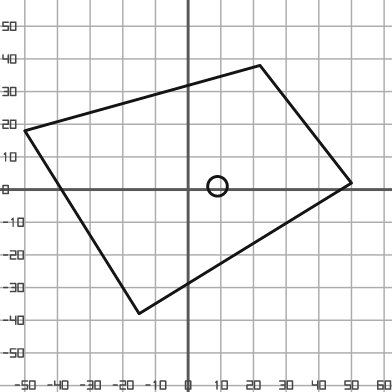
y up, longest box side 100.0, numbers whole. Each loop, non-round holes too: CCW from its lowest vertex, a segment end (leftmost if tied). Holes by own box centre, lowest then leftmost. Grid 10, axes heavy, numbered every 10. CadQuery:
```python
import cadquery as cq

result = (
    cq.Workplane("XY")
    .moveTo(-15.0, -38.0)
    .lineTo(50.0, 2.0)
    .lineTo(22.0, 38.0)
    .lineTo(-50.0, 18.0)
    .close()
    .moveTo(9.0, 1.0)
    .circle(3.0)
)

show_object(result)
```